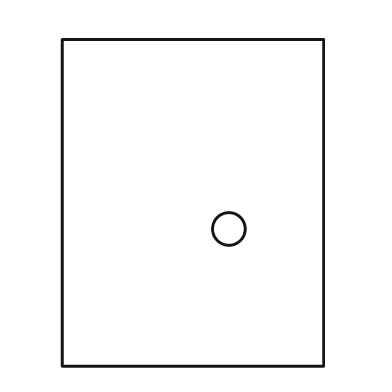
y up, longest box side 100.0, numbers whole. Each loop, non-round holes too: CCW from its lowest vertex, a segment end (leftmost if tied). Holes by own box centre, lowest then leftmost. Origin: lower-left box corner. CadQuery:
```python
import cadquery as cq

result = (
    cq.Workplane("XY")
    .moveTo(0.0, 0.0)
    .lineTo(80.0, 0.0)
    .lineTo(80.0, 100.0)
    .lineTo(0.0, 100.0)
    .close()
    .moveTo(51.0, 42.0)
    .circle(5.0)
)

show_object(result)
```